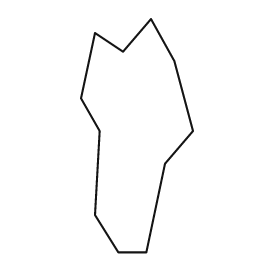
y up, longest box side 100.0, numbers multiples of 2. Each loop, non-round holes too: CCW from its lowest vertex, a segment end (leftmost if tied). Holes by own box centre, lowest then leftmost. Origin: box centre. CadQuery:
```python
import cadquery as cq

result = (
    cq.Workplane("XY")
    .moveTo(-8.0, -50.0)
    .lineTo(4.0, -50.0)
    .lineTo(12.0, -12.0)
    .lineTo(24.0, 2.0)
    .lineTo(16.0, 32.0)
    .lineTo(6.0, 50.0)
    .lineTo(-6.0, 36.0)
    .lineTo(-18.0, 44.0)
    .lineTo(-24.0, 16.0)
    .lineTo(-16.0, 2.0)
    .lineTo(-18.0, -34.0)
    .close()
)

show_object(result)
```